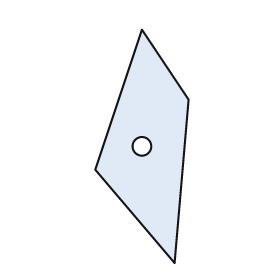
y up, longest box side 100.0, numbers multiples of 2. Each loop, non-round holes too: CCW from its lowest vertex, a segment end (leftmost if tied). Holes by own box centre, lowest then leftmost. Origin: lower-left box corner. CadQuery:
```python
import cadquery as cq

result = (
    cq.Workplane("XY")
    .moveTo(34.0, 0.0)
    .lineTo(40.0, 70.0)
    .lineTo(20.0, 100.0)
    .lineTo(0.0, 40.0)
    .close()
    .moveTo(20.0, 50.0)
    .circle(4.0)
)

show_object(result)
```